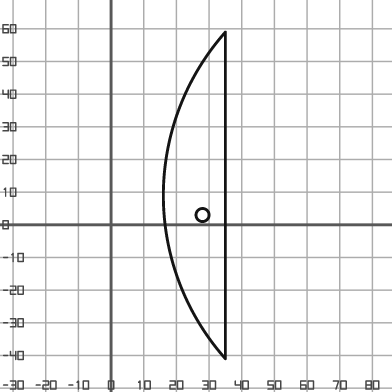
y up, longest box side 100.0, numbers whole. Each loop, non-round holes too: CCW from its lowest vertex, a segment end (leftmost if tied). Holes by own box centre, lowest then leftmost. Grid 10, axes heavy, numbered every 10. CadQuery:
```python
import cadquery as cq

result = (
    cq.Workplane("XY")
    .moveTo(35.0, -41.0)
    .lineTo(35.0, 59.0)
    .threePointArc((16.0, 9.0), (35.0, -41.0))
    .close()
    .moveTo(28.0, 3.0)
    .circle(2.0)
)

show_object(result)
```